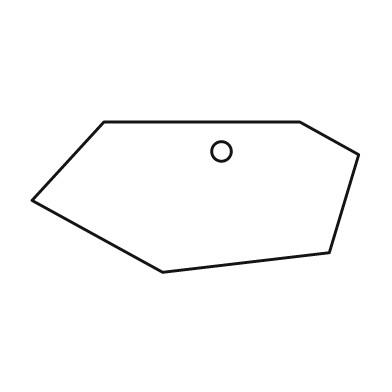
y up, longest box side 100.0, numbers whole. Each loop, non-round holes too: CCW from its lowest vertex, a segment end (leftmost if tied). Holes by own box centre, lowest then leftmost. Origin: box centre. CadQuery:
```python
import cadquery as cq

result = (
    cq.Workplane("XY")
    .moveTo(-10.0, -23.0)
    .lineTo(41.0, -17.0)
    .lineTo(50.0, 13.0)
    .lineTo(32.0, 23.0)
    .lineTo(-28.0, 23.0)
    .lineTo(-50.0, -1.0)
    .close()
    .moveTo(8.0, 14.0)
    .circle(3.0)
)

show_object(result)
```